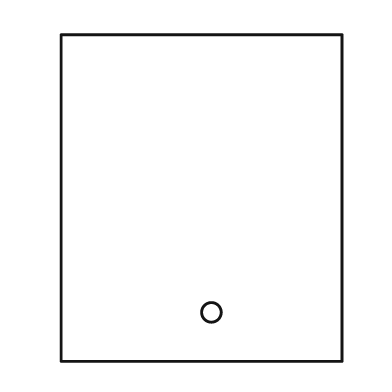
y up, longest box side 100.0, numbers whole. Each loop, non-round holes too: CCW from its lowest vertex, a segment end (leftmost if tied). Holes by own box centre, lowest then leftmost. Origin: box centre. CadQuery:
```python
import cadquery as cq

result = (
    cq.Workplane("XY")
    .moveTo(-43.0, -50.0)
    .lineTo(43.0, -50.0)
    .lineTo(43.0, 50.0)
    .lineTo(-43.0, 50.0)
    .close()
    .moveTo(3.0, -35.0)
    .circle(3.0)
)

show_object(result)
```